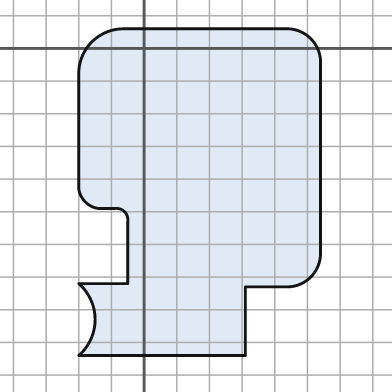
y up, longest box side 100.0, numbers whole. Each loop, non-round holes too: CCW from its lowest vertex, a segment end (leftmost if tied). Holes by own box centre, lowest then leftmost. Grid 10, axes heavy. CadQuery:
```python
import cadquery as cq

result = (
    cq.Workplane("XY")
    .moveTo(-20.0, -94.0)
    .lineTo(31.0, -94.0)
    .lineTo(31.0, -73.0)
    .lineTo(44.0, -73.0)
    .threePointArc((51.0, -70.0), (54.0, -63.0))
    .lineTo(54.0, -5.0)
    .threePointArc((51.0, 3.0), (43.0, 6.0))
    .lineTo(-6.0, 6.0)
    .threePointArc((-16.0, 2.0), (-20.0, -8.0))
    .lineTo(-20.0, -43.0)
    .threePointArc((-18.0, -47.0), (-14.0, -49.0))
    .lineTo(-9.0, -49.0)
    .threePointArc((-6.0, -50.0), (-5.0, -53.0))
    .lineTo(-5.0, -72.0)
    .lineTo(-20.0, -72.0)
    .threePointArc((-15.0, -83.0), (-20.0, -94.0))
    .close()
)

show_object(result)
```